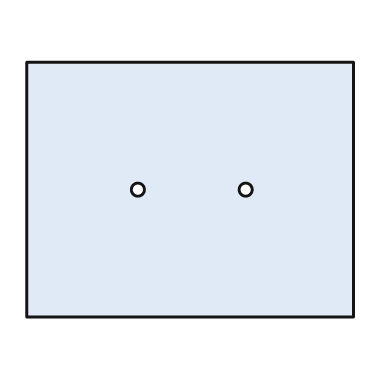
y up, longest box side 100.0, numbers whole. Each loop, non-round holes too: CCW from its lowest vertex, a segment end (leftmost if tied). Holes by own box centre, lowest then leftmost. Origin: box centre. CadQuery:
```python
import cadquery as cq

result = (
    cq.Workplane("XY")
    .moveTo(-50.0, -39.0)
    .lineTo(50.0, -39.0)
    .lineTo(50.0, 39.0)
    .lineTo(-50.0, 39.0)
    .close()
    .moveTo(-16.0, 0.0)
    .circle(2.0)
    .moveTo(17.0, 0.0)
    .circle(2.0)
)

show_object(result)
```